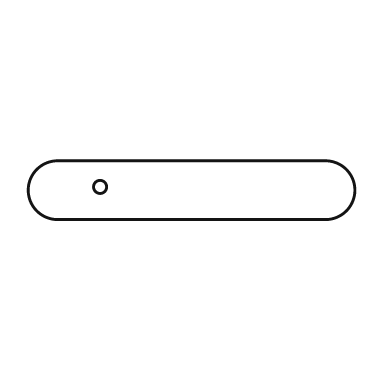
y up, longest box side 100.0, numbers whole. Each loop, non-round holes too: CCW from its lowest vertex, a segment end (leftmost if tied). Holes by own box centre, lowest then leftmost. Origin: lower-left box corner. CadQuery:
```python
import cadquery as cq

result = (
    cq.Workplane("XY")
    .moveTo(9.0, 0.0)
    .lineTo(91.0, 0.0)
    .threePointArc((100.0, 9.0), (91.0, 18.0))
    .lineTo(9.0, 18.0)
    .threePointArc((0.0, 9.0), (9.0, 0.0))
    .close()
    .moveTo(22.0, 10.0)
    .circle(2.0)
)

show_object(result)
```